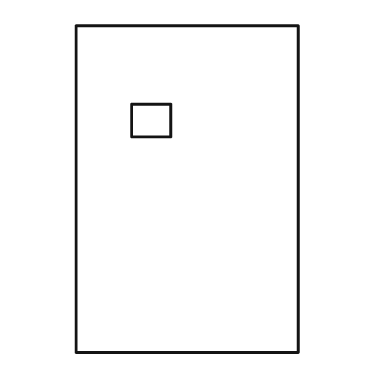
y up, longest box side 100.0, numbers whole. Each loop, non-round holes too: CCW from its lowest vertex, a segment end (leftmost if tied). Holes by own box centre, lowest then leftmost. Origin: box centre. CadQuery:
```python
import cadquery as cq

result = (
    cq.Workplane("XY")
    .moveTo(-34.0, -50.0)
    .lineTo(34.0, -50.0)
    .lineTo(34.0, 50.0)
    .lineTo(-34.0, 50.0)
    .close()
    .moveTo(-17.0, 16.0)
    .lineTo(-5.0, 16.0)
    .lineTo(-5.0, 26.0)
    .lineTo(-17.0, 26.0)
    .close()
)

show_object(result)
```